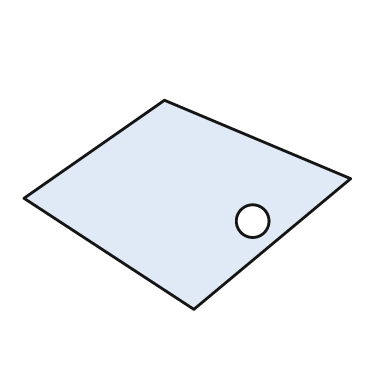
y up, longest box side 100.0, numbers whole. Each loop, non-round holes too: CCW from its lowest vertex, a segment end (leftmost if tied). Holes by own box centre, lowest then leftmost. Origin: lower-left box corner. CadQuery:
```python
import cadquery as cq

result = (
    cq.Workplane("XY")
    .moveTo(52.0, 0.0)
    .lineTo(100.0, 40.0)
    .lineTo(43.0, 64.0)
    .lineTo(0.0, 34.0)
    .close()
    .moveTo(70.0, 27.0)
    .circle(5.0)
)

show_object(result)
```